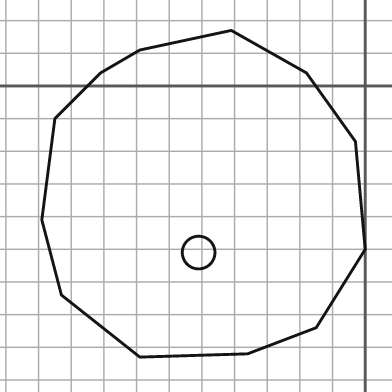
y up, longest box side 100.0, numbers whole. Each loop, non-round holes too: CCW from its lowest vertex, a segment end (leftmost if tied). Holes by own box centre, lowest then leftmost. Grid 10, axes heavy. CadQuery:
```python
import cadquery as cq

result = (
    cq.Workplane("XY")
    .moveTo(-69.0, -83.0)
    .lineTo(-36.0, -82.0)
    .lineTo(-15.0, -74.0)
    .lineTo(0.0, -50.0)
    .lineTo(-3.0, -17.0)
    .lineTo(-18.0, 4.0)
    .lineTo(-41.0, 17.0)
    .lineTo(-69.0, 11.0)
    .lineTo(-81.0, 4.0)
    .lineTo(-95.0, -10.0)
    .lineTo(-99.0, -41.0)
    .lineTo(-93.0, -64.0)
    .close()
    .moveTo(-51.0, -51.0)
    .circle(5.0)
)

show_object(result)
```